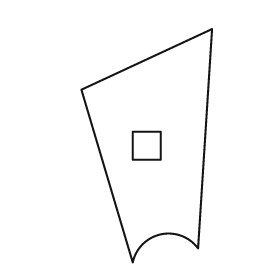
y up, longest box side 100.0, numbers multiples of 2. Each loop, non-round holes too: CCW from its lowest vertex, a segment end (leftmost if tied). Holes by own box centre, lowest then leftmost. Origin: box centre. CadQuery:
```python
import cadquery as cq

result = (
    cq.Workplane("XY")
    .moveTo(-6.0, -50.0)
    .threePointArc((6.0, -38.0), (22.0, -44.0))
    .lineTo(28.0, 50.0)
    .lineTo(-28.0, 24.0)
    .close()
    .moveTo(-6.0, -6.0)
    .lineTo(6.0, -6.0)
    .lineTo(6.0, 6.0)
    .lineTo(-6.0, 6.0)
    .close()
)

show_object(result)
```